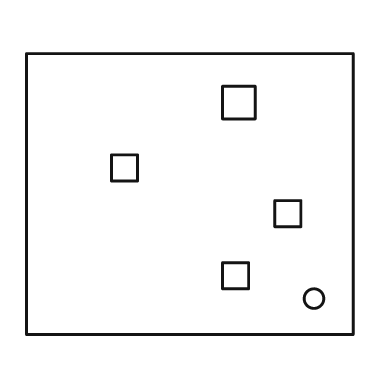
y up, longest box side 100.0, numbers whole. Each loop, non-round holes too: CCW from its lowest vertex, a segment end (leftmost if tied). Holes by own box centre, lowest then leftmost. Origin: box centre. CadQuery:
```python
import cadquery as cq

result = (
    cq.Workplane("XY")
    .moveTo(-50.0, -43.0)
    .lineTo(50.0, -43.0)
    .lineTo(50.0, 43.0)
    .lineTo(-50.0, 43.0)
    .close()
    .moveTo(38.0, -32.0)
    .circle(3.0)
    .moveTo(10.0, -29.0)
    .lineTo(18.0, -29.0)
    .lineTo(18.0, -21.0)
    .lineTo(10.0, -21.0)
    .close()
    .moveTo(26.0, -10.0)
    .lineTo(34.0, -10.0)
    .lineTo(34.0, -2.0)
    .lineTo(26.0, -2.0)
    .close()
    .moveTo(-24.0, 4.0)
    .lineTo(-16.0, 4.0)
    .lineTo(-16.0, 12.0)
    .lineTo(-24.0, 12.0)
    .close()
    .moveTo(10.0, 23.0)
    .lineTo(20.0, 23.0)
    .lineTo(20.0, 33.0)
    .lineTo(10.0, 33.0)
    .close()
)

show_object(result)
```